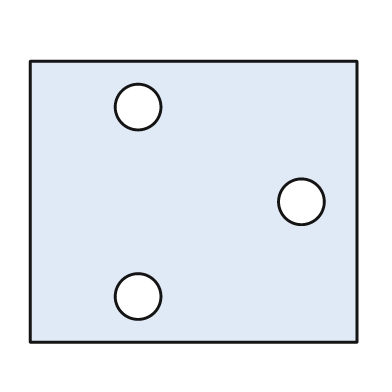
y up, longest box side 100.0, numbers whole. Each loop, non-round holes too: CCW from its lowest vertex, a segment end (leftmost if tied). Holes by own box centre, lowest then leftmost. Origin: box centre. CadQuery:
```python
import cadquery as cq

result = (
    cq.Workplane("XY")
    .moveTo(-50.0, -43.0)
    .lineTo(50.0, -43.0)
    .lineTo(50.0, 43.0)
    .lineTo(-50.0, 43.0)
    .close()
    .moveTo(-17.0, -29.0)
    .circle(7.0)
    .moveTo(33.0, 0.0)
    .circle(7.0)
    .moveTo(-17.0, 29.0)
    .circle(7.0)
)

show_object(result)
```